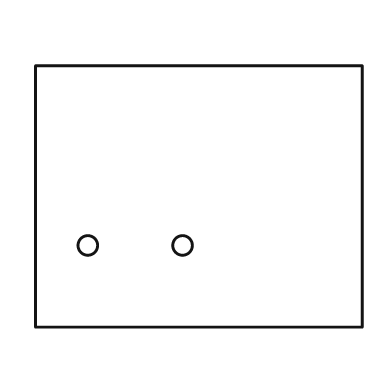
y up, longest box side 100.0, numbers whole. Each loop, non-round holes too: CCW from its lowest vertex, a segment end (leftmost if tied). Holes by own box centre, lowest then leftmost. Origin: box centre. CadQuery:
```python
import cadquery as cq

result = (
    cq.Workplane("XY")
    .moveTo(-50.0, -40.0)
    .lineTo(50.0, -40.0)
    .lineTo(50.0, 40.0)
    .lineTo(-50.0, 40.0)
    .close()
    .moveTo(-34.0, -15.0)
    .circle(3.0)
    .moveTo(-5.0, -15.0)
    .circle(3.0)
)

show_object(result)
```